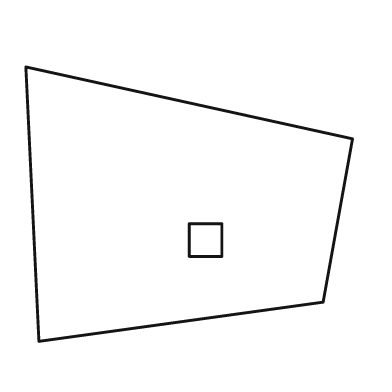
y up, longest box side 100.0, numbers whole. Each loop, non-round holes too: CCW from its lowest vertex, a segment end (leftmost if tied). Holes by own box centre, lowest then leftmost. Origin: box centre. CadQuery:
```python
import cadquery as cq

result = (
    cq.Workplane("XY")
    .moveTo(-46.0, -42.0)
    .lineTo(41.0, -30.0)
    .lineTo(50.0, 20.0)
    .lineTo(-50.0, 42.0)
    .close()
    .moveTo(0.0, -16.0)
    .lineTo(10.0, -16.0)
    .lineTo(10.0, -6.0)
    .lineTo(0.0, -6.0)
    .close()
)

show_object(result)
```